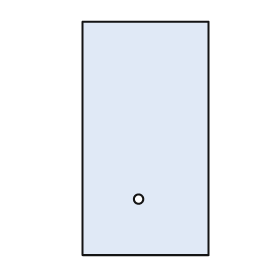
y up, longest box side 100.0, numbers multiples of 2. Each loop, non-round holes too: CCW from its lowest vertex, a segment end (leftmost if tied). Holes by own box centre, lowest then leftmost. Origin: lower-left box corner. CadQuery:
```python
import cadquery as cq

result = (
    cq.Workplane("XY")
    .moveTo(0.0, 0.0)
    .lineTo(54.0, 0.0)
    .lineTo(54.0, 100.0)
    .lineTo(0.0, 100.0)
    .close()
    .moveTo(24.0, 24.0)
    .circle(2.0)
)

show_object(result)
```